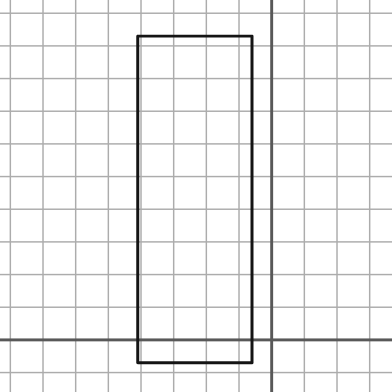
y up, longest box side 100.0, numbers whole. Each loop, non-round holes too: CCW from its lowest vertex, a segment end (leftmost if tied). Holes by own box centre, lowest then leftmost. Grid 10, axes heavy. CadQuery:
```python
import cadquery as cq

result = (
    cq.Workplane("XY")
    .moveTo(-41.0, -7.0)
    .lineTo(-6.0, -7.0)
    .lineTo(-6.0, 93.0)
    .lineTo(-41.0, 93.0)
    .close()
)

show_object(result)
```